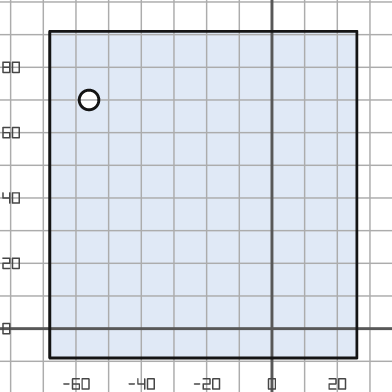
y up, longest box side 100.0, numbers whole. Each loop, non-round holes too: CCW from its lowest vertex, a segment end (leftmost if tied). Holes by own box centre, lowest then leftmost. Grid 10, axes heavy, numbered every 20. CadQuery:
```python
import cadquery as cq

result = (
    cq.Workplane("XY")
    .moveTo(-68.0, -9.0)
    .lineTo(26.0, -9.0)
    .lineTo(26.0, 91.0)
    .lineTo(-68.0, 91.0)
    .close()
    .moveTo(-56.0, 70.0)
    .circle(3.0)
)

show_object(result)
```